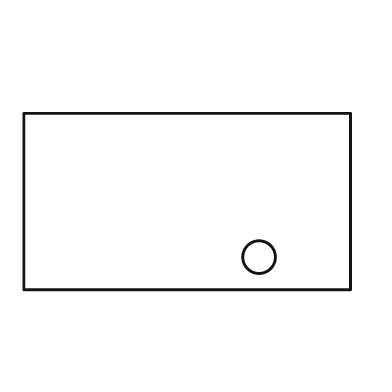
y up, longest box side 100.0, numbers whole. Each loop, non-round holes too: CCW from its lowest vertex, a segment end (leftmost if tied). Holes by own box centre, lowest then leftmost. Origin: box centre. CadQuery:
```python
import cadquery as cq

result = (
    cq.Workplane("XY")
    .moveTo(-50.0, -27.0)
    .lineTo(50.0, -27.0)
    .lineTo(50.0, 27.0)
    .lineTo(-50.0, 27.0)
    .close()
    .moveTo(22.0, -17.0)
    .circle(5.0)
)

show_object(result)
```